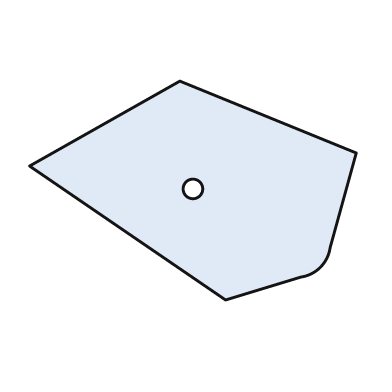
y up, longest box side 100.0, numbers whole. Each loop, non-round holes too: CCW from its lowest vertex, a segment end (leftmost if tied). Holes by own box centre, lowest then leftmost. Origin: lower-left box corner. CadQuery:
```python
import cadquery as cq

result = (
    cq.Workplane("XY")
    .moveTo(60.0, 0.0)
    .lineTo(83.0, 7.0)
    .threePointArc((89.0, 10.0), (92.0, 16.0))
    .lineTo(100.0, 45.0)
    .lineTo(46.0, 67.0)
    .lineTo(0.0, 41.0)
    .close()
    .moveTo(50.0, 34.0)
    .circle(3.0)
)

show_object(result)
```